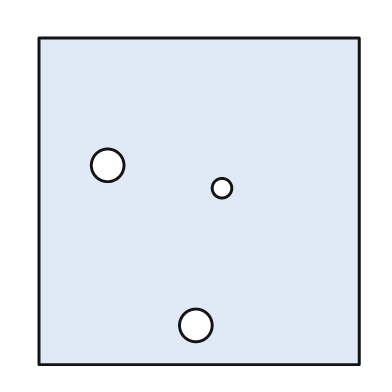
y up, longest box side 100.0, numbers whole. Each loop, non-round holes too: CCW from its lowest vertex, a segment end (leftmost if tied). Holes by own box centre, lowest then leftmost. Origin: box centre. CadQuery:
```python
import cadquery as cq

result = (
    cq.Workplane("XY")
    .moveTo(-49.0, -50.0)
    .lineTo(49.0, -50.0)
    .lineTo(49.0, 50.0)
    .lineTo(-49.0, 50.0)
    .close()
    .moveTo(-1.0, -38.0)
    .circle(5.0)
    .moveTo(7.0, 4.0)
    .circle(3.0)
    .moveTo(-28.0, 11.0)
    .circle(5.0)
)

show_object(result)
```